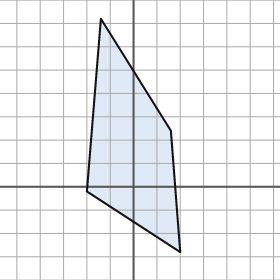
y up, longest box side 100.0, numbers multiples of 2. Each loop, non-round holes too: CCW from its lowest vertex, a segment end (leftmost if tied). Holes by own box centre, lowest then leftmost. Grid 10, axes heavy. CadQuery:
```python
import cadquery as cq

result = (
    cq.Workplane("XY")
    .moveTo(20.0, -28.0)
    .lineTo(16.0, 24.0)
    .lineTo(-14.0, 72.0)
    .lineTo(-20.0, -2.0)
    .close()
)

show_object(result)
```